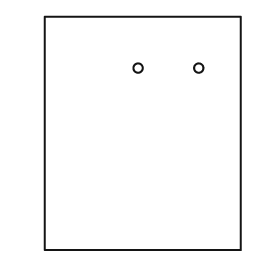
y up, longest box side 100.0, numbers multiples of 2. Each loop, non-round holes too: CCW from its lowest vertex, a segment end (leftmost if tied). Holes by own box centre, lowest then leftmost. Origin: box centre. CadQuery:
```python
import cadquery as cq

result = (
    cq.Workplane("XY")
    .moveTo(-42.0, -50.0)
    .lineTo(42.0, -50.0)
    .lineTo(42.0, 50.0)
    .lineTo(-42.0, 50.0)
    .close()
    .moveTo(-2.0, 28.0)
    .circle(2.0)
    .moveTo(24.0, 28.0)
    .circle(2.0)
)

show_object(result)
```